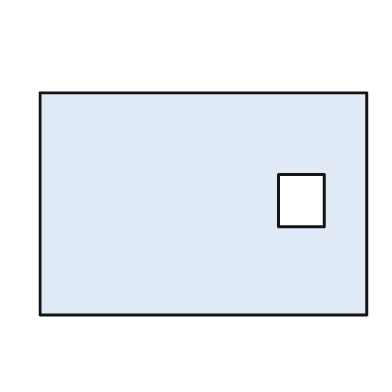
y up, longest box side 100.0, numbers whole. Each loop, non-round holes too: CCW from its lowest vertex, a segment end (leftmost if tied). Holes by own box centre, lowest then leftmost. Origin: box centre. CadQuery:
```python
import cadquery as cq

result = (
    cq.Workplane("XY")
    .moveTo(-50.0, -34.0)
    .lineTo(50.0, -34.0)
    .lineTo(50.0, 34.0)
    .lineTo(-50.0, 34.0)
    .close()
    .moveTo(23.0, -7.0)
    .lineTo(37.0, -7.0)
    .lineTo(37.0, 9.0)
    .lineTo(23.0, 9.0)
    .close()
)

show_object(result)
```